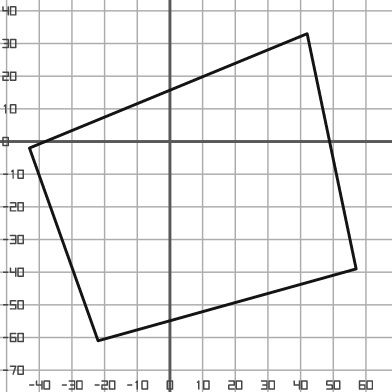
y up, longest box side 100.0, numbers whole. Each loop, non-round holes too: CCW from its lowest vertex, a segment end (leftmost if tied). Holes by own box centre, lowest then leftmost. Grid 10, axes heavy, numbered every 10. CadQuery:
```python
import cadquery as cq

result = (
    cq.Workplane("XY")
    .moveTo(-22.0, -61.0)
    .lineTo(57.0, -39.0)
    .lineTo(42.0, 33.0)
    .lineTo(-43.0, -2.0)
    .close()
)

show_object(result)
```